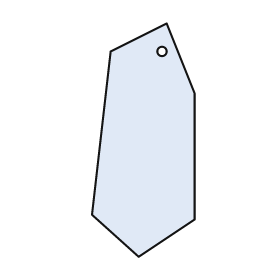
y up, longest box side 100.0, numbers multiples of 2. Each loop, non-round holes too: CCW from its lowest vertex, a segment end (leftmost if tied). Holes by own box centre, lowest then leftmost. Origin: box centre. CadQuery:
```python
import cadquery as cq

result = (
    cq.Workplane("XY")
    .moveTo(-2.0, -50.0)
    .lineTo(22.0, -34.0)
    .lineTo(22.0, 20.0)
    .lineTo(10.0, 50.0)
    .lineTo(-14.0, 38.0)
    .lineTo(-22.0, -32.0)
    .close()
    .moveTo(8.0, 38.0)
    .circle(2.0)
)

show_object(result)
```